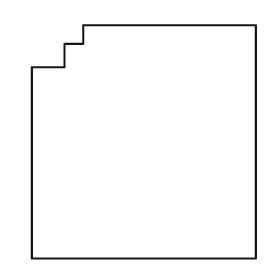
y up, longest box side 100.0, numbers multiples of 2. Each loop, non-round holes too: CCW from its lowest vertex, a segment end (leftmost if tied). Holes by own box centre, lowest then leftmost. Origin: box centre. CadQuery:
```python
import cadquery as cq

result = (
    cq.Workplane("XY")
    .moveTo(-48.0, -50.0)
    .lineTo(48.0, -50.0)
    .lineTo(48.0, 50.0)
    .lineTo(-26.0, 50.0)
    .lineTo(-26.0, 42.0)
    .lineTo(-34.0, 42.0)
    .lineTo(-34.0, 32.0)
    .lineTo(-48.0, 32.0)
    .close()
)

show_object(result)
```